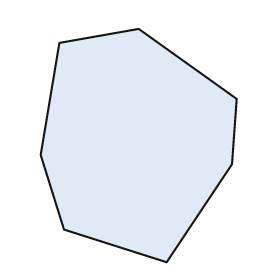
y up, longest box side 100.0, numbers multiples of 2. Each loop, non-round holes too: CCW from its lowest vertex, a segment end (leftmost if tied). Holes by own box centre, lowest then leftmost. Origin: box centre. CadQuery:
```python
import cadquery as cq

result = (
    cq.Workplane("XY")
    .moveTo(12.0, -50.0)
    .lineTo(40.0, -8.0)
    .lineTo(42.0, 20.0)
    .lineTo(0.0, 50.0)
    .lineTo(-34.0, 44.0)
    .lineTo(-42.0, -4.0)
    .lineTo(-32.0, -36.0)
    .close()
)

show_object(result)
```